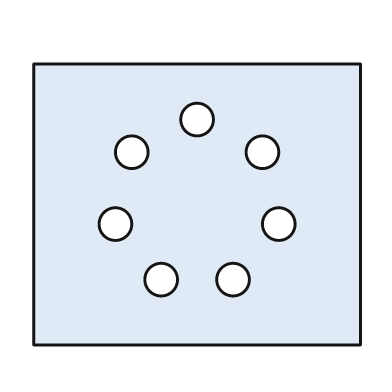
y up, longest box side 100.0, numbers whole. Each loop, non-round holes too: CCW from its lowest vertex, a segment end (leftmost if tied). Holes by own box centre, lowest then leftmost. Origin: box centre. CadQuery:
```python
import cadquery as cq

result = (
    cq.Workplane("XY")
    .moveTo(-50.0, -43.0)
    .lineTo(50.0, -43.0)
    .lineTo(50.0, 43.0)
    .lineTo(-50.0, 43.0)
    .close()
    .moveTo(-11.0, -23.0)
    .circle(5.0)
    .moveTo(11.0, -23.0)
    .circle(5.0)
    .moveTo(-25.0, -6.0)
    .circle(5.0)
    .moveTo(25.0, -6.0)
    .circle(5.0)
    .moveTo(-20.0, 16.0)
    .circle(5.0)
    .moveTo(20.0, 16.0)
    .circle(5.0)
    .moveTo(0.0, 26.0)
    .circle(5.0)
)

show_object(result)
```